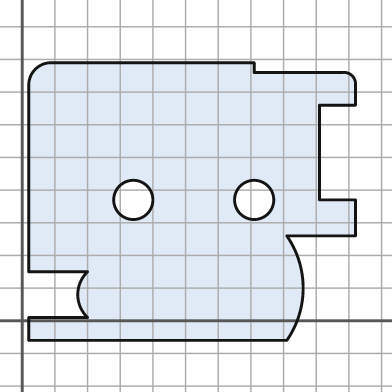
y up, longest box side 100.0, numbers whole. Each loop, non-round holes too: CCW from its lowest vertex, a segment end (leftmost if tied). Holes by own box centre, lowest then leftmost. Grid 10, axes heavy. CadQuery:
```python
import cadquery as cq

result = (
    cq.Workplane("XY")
    .moveTo(2.0, -6.0)
    .lineTo(81.0, -6.0)
    .threePointArc((86.0, 10.0), (81.0, 26.0))
    .lineTo(102.0, 26.0)
    .lineTo(102.0, 37.0)
    .lineTo(91.0, 37.0)
    .lineTo(91.0, 66.0)
    .lineTo(102.0, 66.0)
    .lineTo(102.0, 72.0)
    .threePointArc((101.0, 75.0), (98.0, 76.0))
    .lineTo(71.0, 76.0)
    .lineTo(71.0, 79.0)
    .lineTo(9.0, 79.0)
    .threePointArc((4.0, 77.0), (2.0, 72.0))
    .lineTo(2.0, 15.0)
    .lineTo(20.0, 15.0)
    .threePointArc((17.0, 8.0), (20.0, 1.0))
    .lineTo(2.0, 1.0)
    .close()
    .moveTo(34.0, 37.0)
    .circle(6.0)
    .moveTo(71.0, 37.0)
    .circle(6.0)
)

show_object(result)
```